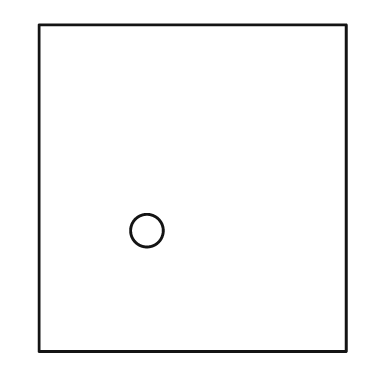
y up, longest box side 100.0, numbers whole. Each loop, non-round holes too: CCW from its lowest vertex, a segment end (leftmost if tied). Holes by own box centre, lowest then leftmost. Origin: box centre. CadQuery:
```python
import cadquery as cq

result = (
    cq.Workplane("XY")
    .moveTo(-47.0, -50.0)
    .lineTo(47.0, -50.0)
    .lineTo(47.0, 50.0)
    .lineTo(-47.0, 50.0)
    .close()
    .moveTo(-14.0, -13.0)
    .circle(5.0)
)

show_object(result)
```